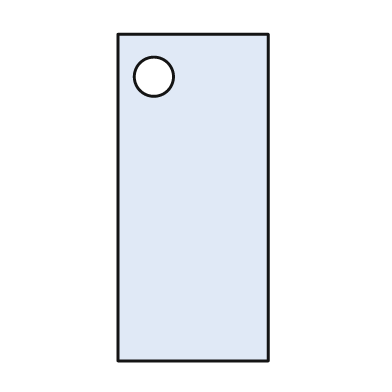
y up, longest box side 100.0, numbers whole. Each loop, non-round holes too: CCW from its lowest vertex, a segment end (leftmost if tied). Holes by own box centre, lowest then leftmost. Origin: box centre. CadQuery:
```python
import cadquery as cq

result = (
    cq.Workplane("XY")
    .moveTo(-23.0, -50.0)
    .lineTo(23.0, -50.0)
    .lineTo(23.0, 50.0)
    .lineTo(-23.0, 50.0)
    .close()
    .moveTo(-12.0, 37.0)
    .circle(6.0)
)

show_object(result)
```